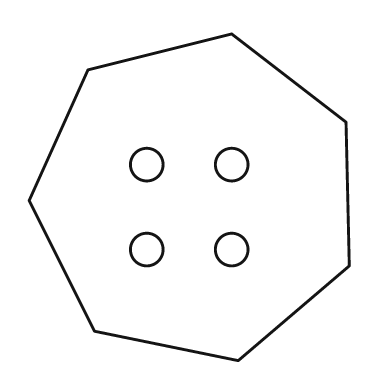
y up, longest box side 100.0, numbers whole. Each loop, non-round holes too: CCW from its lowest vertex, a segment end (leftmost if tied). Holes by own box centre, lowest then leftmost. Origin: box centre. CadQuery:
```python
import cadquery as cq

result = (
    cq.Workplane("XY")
    .moveTo(15.0, -50.0)
    .lineTo(49.0, -21.0)
    .lineTo(48.0, 23.0)
    .lineTo(13.0, 50.0)
    .lineTo(-31.0, 39.0)
    .lineTo(-49.0, -1.0)
    .lineTo(-29.0, -41.0)
    .close()
    .moveTo(-13.0, -16.0)
    .circle(5.0)
    .moveTo(13.0, -16.0)
    .circle(5.0)
    .moveTo(-13.0, 10.0)
    .circle(5.0)
    .moveTo(13.0, 10.0)
    .circle(5.0)
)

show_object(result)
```